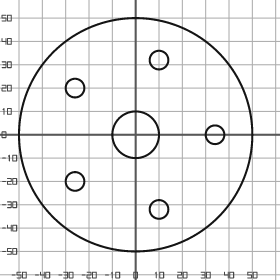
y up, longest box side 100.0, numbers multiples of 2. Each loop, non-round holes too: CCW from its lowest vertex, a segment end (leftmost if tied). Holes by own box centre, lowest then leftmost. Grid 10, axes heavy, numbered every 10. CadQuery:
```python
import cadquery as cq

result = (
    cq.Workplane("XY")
    .moveTo(0.0, 0.0)
    .circle(50.0)
    .moveTo(10.0, -32.0)
    .circle(4.0)
    .moveTo(-26.0, -20.0)
    .circle(4.0)
    .moveTo(0.0, 0.0)
    .circle(10.0)
    .moveTo(34.0, 0.0)
    .circle(4.0)
    .moveTo(-26.0, 20.0)
    .circle(4.0)
    .moveTo(10.0, 32.0)
    .circle(4.0)
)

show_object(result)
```